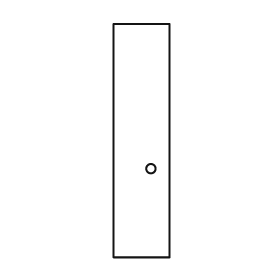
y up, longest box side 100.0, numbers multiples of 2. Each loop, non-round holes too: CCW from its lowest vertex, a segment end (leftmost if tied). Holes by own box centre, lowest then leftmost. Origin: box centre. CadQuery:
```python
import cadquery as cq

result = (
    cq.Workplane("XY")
    .moveTo(-12.0, -50.0)
    .lineTo(12.0, -50.0)
    .lineTo(12.0, 50.0)
    .lineTo(-12.0, 50.0)
    .close()
    .moveTo(4.0, -12.0)
    .circle(2.0)
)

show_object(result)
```